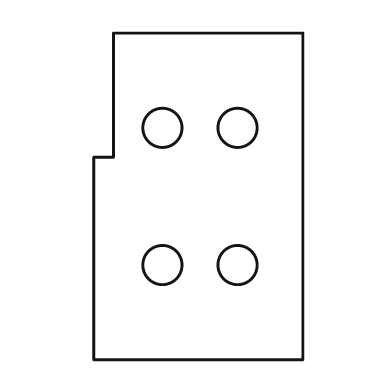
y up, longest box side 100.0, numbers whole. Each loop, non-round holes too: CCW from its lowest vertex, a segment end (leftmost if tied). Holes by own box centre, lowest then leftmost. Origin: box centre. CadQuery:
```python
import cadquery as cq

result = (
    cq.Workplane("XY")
    .moveTo(-32.0, -50.0)
    .lineTo(32.0, -50.0)
    .lineTo(32.0, 50.0)
    .lineTo(-26.0, 50.0)
    .lineTo(-26.0, 12.0)
    .lineTo(-32.0, 12.0)
    .close()
    .moveTo(-11.0, -21.0)
    .circle(6.0)
    .moveTo(12.0, -21.0)
    .circle(6.0)
    .moveTo(-11.0, 21.0)
    .circle(6.0)
    .moveTo(12.0, 21.0)
    .circle(6.0)
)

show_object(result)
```